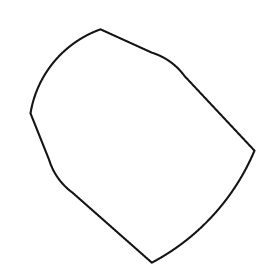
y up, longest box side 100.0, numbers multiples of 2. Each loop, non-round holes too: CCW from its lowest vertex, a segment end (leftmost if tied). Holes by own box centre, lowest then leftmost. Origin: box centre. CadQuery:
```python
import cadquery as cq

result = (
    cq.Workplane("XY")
    .moveTo(4.0, -50.0)
    .threePointArc((30.0, -30.0), (48.0, -2.0))
    .lineTo(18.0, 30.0)
    .threePointArc((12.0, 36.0), (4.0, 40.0))
    .lineTo(-18.0, 50.0)
    .threePointArc((-38.0, 36.0), (-48.0, 14.0))
    .lineTo(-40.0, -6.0)
    .threePointArc((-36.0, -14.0), (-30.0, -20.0))
    .close()
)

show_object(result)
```